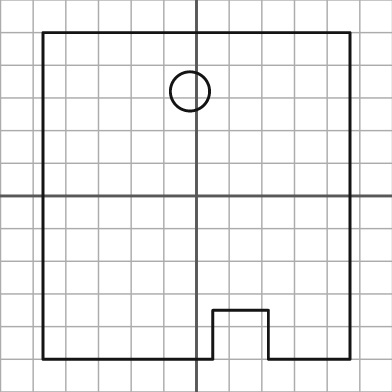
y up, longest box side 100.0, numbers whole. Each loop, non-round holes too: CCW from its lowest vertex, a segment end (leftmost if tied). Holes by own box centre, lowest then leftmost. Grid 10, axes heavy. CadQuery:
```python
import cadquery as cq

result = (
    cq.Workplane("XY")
    .moveTo(-47.0, -50.0)
    .lineTo(5.0, -50.0)
    .lineTo(5.0, -35.0)
    .lineTo(22.0, -35.0)
    .lineTo(22.0, -50.0)
    .lineTo(47.0, -50.0)
    .lineTo(47.0, 50.0)
    .lineTo(-47.0, 50.0)
    .close()
    .moveTo(-2.0, 32.0)
    .circle(6.0)
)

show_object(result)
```